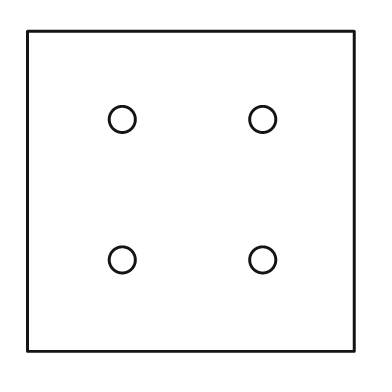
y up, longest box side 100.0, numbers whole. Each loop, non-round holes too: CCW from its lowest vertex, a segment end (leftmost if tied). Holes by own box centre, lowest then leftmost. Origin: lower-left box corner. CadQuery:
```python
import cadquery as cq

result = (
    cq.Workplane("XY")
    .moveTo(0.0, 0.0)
    .lineTo(100.0, 0.0)
    .lineTo(100.0, 98.0)
    .lineTo(0.0, 98.0)
    .close()
    .moveTo(29.0, 28.0)
    .circle(4.0)
    .moveTo(72.0, 28.0)
    .circle(4.0)
    .moveTo(29.0, 71.0)
    .circle(4.0)
    .moveTo(72.0, 71.0)
    .circle(4.0)
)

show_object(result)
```